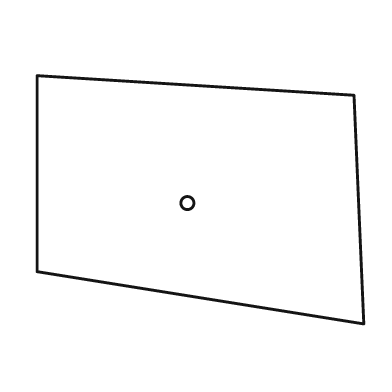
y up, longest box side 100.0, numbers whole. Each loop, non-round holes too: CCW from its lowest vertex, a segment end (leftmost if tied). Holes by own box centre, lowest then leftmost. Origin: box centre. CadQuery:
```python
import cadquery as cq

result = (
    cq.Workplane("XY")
    .moveTo(50.0, -38.0)
    .lineTo(47.0, 32.0)
    .lineTo(-50.0, 38.0)
    .lineTo(-50.0, -22.0)
    .close()
    .moveTo(-4.0, -1.0)
    .circle(2.0)
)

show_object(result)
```